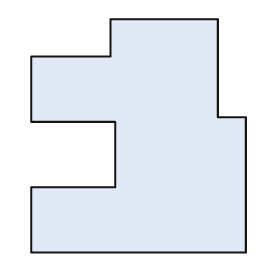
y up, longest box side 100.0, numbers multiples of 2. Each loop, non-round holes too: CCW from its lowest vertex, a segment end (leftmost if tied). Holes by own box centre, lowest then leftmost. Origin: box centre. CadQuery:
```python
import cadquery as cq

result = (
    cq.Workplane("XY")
    .moveTo(-46.0, -50.0)
    .lineTo(46.0, -50.0)
    .lineTo(46.0, 8.0)
    .lineTo(34.0, 8.0)
    .lineTo(34.0, 50.0)
    .lineTo(-12.0, 50.0)
    .lineTo(-12.0, 34.0)
    .lineTo(-46.0, 34.0)
    .lineTo(-46.0, 6.0)
    .lineTo(-10.0, 6.0)
    .lineTo(-10.0, -22.0)
    .lineTo(-46.0, -22.0)
    .close()
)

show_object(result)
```